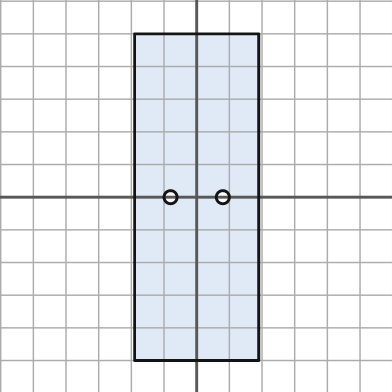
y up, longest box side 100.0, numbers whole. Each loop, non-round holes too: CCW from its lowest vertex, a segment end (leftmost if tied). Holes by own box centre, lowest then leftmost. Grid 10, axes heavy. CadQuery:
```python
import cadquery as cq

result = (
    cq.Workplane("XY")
    .moveTo(-19.0, -50.0)
    .lineTo(19.0, -50.0)
    .lineTo(19.0, 50.0)
    .lineTo(-19.0, 50.0)
    .close()
    .moveTo(-8.0, 0.0)
    .circle(2.0)
    .moveTo(8.0, 0.0)
    .circle(2.0)
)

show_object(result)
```